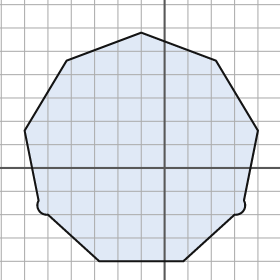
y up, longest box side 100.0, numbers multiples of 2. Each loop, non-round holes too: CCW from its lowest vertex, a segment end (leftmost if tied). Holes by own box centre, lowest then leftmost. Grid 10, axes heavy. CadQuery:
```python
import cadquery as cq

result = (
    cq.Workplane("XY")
    .moveTo(-28.0, -40.0)
    .lineTo(8.0, -40.0)
    .lineTo(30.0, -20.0)
    .threePointArc((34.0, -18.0), (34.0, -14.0))
    .lineTo(40.0, 16.0)
    .lineTo(22.0, 46.0)
    .lineTo(-10.0, 58.0)
    .lineTo(-42.0, 46.0)
    .lineTo(-60.0, 16.0)
    .lineTo(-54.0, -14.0)
    .threePointArc((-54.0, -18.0), (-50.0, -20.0))
    .close()
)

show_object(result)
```